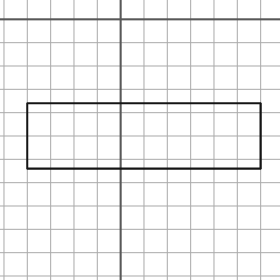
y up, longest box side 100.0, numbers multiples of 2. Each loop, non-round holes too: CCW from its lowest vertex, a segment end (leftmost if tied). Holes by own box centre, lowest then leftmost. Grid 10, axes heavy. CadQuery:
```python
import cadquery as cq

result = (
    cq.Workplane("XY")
    .moveTo(-40.0, -64.0)
    .lineTo(60.0, -64.0)
    .lineTo(60.0, -36.0)
    .lineTo(-40.0, -36.0)
    .close()
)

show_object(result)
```